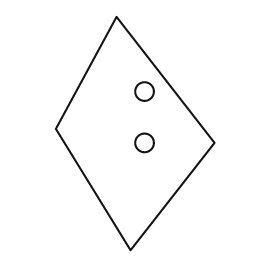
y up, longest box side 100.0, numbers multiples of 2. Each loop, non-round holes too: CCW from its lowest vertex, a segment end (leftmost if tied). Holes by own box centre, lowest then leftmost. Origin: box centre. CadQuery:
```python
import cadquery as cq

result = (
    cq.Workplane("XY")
    .moveTo(-2.0, -50.0)
    .lineTo(34.0, -4.0)
    .lineTo(-8.0, 50.0)
    .lineTo(-34.0, 2.0)
    .close()
    .moveTo(4.0, -4.0)
    .circle(4.0)
    .moveTo(4.0, 18.0)
    .circle(4.0)
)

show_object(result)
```